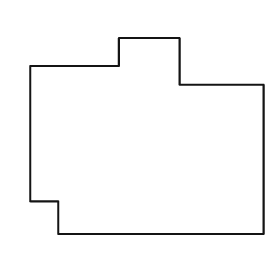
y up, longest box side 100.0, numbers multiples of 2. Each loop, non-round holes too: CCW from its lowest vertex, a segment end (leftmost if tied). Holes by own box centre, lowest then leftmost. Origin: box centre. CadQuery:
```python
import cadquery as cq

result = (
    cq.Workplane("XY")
    .moveTo(-38.0, -42.0)
    .lineTo(50.0, -42.0)
    .lineTo(50.0, 22.0)
    .lineTo(14.0, 22.0)
    .lineTo(14.0, 42.0)
    .lineTo(-12.0, 42.0)
    .lineTo(-12.0, 30.0)
    .lineTo(-50.0, 30.0)
    .lineTo(-50.0, -28.0)
    .lineTo(-38.0, -28.0)
    .close()
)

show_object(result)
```